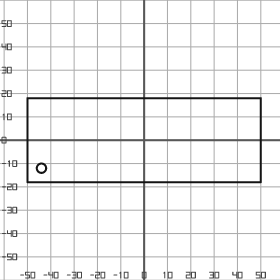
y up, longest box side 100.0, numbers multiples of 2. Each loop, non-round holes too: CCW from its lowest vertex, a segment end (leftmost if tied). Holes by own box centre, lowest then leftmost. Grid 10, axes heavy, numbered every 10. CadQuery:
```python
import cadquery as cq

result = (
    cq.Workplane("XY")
    .moveTo(-50.0, -18.0)
    .lineTo(50.0, -18.0)
    .lineTo(50.0, 18.0)
    .lineTo(-50.0, 18.0)
    .close()
    .moveTo(-44.0, -12.0)
    .circle(2.0)
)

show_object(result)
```